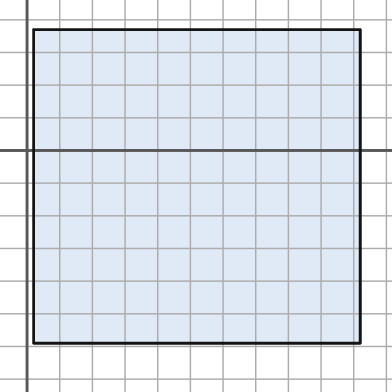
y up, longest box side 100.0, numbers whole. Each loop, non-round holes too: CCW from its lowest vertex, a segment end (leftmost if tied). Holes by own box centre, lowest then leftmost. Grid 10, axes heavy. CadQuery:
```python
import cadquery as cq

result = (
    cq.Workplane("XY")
    .moveTo(2.0, -59.0)
    .lineTo(102.0, -59.0)
    .lineTo(102.0, 37.0)
    .lineTo(2.0, 37.0)
    .close()
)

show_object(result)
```